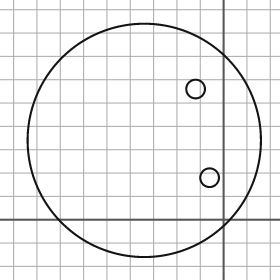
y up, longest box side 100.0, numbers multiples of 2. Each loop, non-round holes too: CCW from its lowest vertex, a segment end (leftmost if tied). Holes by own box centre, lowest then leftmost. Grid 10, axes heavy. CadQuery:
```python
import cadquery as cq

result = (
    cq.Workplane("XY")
    .moveTo(-34.0, 34.0)
    .circle(50.0)
    .moveTo(-6.0, 18.0)
    .circle(4.0)
    .moveTo(-12.0, 56.0)
    .circle(4.0)
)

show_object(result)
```